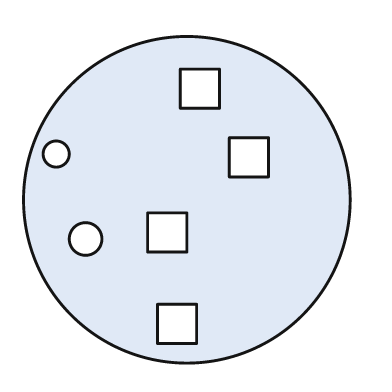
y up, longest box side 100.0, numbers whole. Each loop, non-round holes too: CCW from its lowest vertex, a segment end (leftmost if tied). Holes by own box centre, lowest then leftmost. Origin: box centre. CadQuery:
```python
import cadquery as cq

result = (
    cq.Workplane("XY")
    .moveTo(0.0, 0.0)
    .circle(50.0)
    .moveTo(-9.0, -44.0)
    .lineTo(3.0, -44.0)
    .lineTo(3.0, -32.0)
    .lineTo(-9.0, -32.0)
    .close()
    .moveTo(-31.0, -12.0)
    .circle(5.0)
    .moveTo(-12.0, -16.0)
    .lineTo(0.0, -16.0)
    .lineTo(0.0, -4.0)
    .lineTo(-12.0, -4.0)
    .close()
    .moveTo(13.0, 7.0)
    .lineTo(25.0, 7.0)
    .lineTo(25.0, 19.0)
    .lineTo(13.0, 19.0)
    .close()
    .moveTo(-40.0, 14.0)
    .circle(4.0)
    .moveTo(-2.0, 28.0)
    .lineTo(10.0, 28.0)
    .lineTo(10.0, 40.0)
    .lineTo(-2.0, 40.0)
    .close()
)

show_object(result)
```